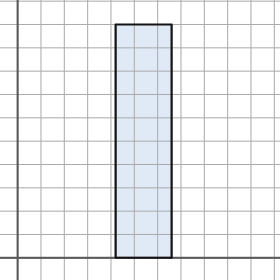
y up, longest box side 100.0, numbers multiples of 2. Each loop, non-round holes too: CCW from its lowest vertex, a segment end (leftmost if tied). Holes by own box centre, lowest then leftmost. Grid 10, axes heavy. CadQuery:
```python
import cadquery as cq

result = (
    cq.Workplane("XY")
    .moveTo(42.0, 0.0)
    .lineTo(66.0, 0.0)
    .lineTo(66.0, 100.0)
    .lineTo(42.0, 100.0)
    .close()
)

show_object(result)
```